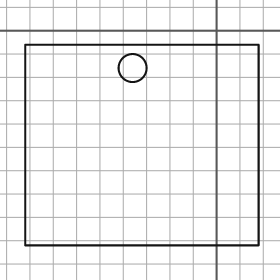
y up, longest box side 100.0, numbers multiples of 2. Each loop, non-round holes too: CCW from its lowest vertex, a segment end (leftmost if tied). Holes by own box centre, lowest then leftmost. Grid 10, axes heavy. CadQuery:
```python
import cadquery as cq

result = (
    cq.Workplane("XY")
    .moveTo(-82.0, -92.0)
    .lineTo(18.0, -92.0)
    .lineTo(18.0, -6.0)
    .lineTo(-82.0, -6.0)
    .close()
    .moveTo(-36.0, -16.0)
    .circle(6.0)
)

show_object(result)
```